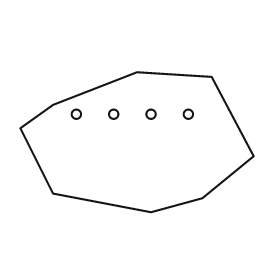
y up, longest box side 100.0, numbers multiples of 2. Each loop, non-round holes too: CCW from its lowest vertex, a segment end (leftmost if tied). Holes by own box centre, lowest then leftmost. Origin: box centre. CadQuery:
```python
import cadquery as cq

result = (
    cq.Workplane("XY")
    .moveTo(6.0, -30.0)
    .lineTo(28.0, -24.0)
    .lineTo(50.0, -6.0)
    .lineTo(32.0, 28.0)
    .lineTo(0.0, 30.0)
    .lineTo(-36.0, 16.0)
    .lineTo(-50.0, 6.0)
    .lineTo(-36.0, -22.0)
    .close()
    .moveTo(-26.0, 12.0)
    .circle(2.0)
    .moveTo(-10.0, 12.0)
    .circle(2.0)
    .moveTo(6.0, 12.0)
    .circle(2.0)
    .moveTo(22.0, 12.0)
    .circle(2.0)
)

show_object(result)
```